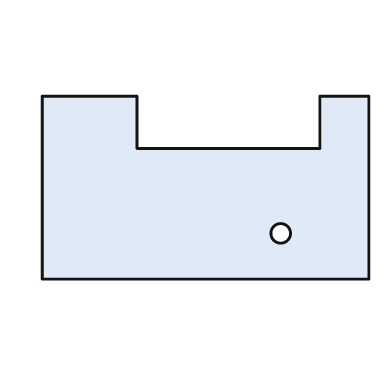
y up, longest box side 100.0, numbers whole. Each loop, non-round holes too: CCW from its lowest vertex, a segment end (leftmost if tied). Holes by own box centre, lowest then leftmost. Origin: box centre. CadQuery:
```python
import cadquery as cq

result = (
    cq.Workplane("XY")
    .moveTo(-50.0, -28.0)
    .lineTo(50.0, -28.0)
    .lineTo(50.0, 28.0)
    .lineTo(35.0, 28.0)
    .lineTo(35.0, 12.0)
    .lineTo(-21.0, 12.0)
    .lineTo(-21.0, 28.0)
    .lineTo(-50.0, 28.0)
    .close()
    .moveTo(23.0, -14.0)
    .circle(3.0)
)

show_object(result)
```